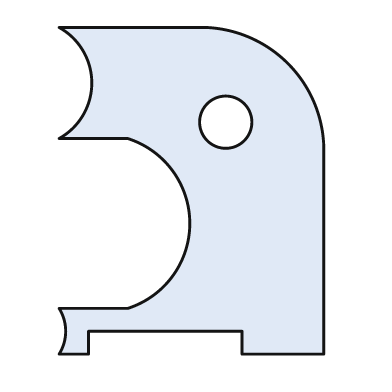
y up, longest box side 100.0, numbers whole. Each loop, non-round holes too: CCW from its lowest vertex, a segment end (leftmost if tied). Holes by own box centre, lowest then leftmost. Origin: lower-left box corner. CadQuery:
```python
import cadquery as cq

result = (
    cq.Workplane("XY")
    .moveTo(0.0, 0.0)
    .lineTo(9.0, 0.0)
    .lineTo(9.0, 7.0)
    .lineTo(56.0, 7.0)
    .lineTo(56.0, 0.0)
    .lineTo(81.0, 0.0)
    .lineTo(81.0, 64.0)
    .threePointArc((70.0, 89.0), (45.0, 100.0))
    .lineTo(0.0, 100.0)
    .threePointArc((10.0, 83.0), (0.0, 66.0))
    .lineTo(21.0, 66.0)
    .threePointArc((40.0, 40.0), (21.0, 14.0))
    .lineTo(0.0, 14.0)
    .threePointArc((2.0, 7.0), (0.0, 0.0))
    .close()
    .moveTo(51.0, 71.0)
    .circle(8.0)
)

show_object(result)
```